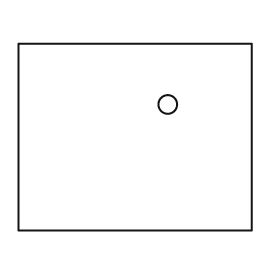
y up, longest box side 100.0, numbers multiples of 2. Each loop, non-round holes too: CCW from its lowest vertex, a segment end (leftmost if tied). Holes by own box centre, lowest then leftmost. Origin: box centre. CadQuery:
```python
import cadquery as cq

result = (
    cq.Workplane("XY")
    .moveTo(-50.0, -40.0)
    .lineTo(50.0, -40.0)
    .lineTo(50.0, 40.0)
    .lineTo(-50.0, 40.0)
    .close()
    .moveTo(14.0, 14.0)
    .circle(4.0)
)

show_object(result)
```